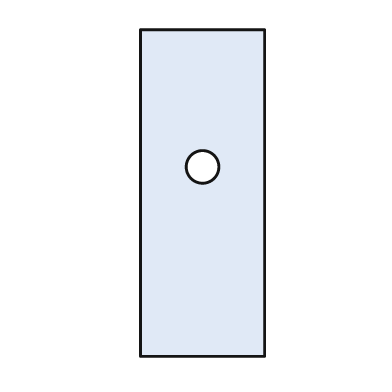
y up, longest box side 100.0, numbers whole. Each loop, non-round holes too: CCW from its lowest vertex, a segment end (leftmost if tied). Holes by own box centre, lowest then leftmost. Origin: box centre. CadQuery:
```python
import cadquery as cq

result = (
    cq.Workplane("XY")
    .moveTo(-19.0, -50.0)
    .lineTo(19.0, -50.0)
    .lineTo(19.0, 50.0)
    .lineTo(-19.0, 50.0)
    .close()
    .moveTo(0.0, 8.0)
    .circle(5.0)
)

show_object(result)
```